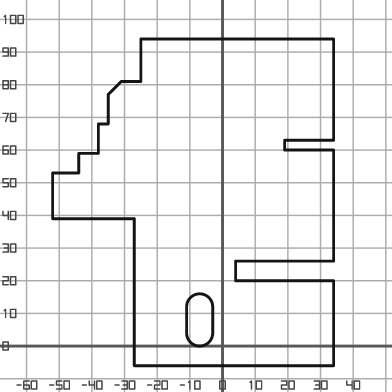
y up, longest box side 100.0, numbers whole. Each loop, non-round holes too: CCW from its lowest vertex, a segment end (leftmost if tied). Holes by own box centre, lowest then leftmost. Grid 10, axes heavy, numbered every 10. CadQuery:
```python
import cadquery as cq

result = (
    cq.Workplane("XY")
    .moveTo(-27.0, -6.0)
    .lineTo(34.0, -6.0)
    .lineTo(34.0, 20.0)
    .lineTo(4.0, 20.0)
    .lineTo(4.0, 26.0)
    .lineTo(34.0, 26.0)
    .lineTo(34.0, 60.0)
    .lineTo(19.0, 60.0)
    .lineTo(19.0, 63.0)
    .lineTo(34.0, 63.0)
    .lineTo(34.0, 94.0)
    .lineTo(-25.0, 94.0)
    .lineTo(-25.0, 81.0)
    .lineTo(-31.0, 81.0)
    .lineTo(-35.0, 77.0)
    .lineTo(-35.0, 68.0)
    .lineTo(-38.0, 68.0)
    .lineTo(-38.0, 59.0)
    .lineTo(-44.0, 59.0)
    .lineTo(-44.0, 53.0)
    .lineTo(-52.0, 53.0)
    .lineTo(-52.0, 39.0)
    .lineTo(-27.0, 39.0)
    .close()
    .moveTo(-11.0, 4.0)
    .threePointArc((-7.0, 0.0), (-3.0, 4.0))
    .lineTo(-3.0, 12.0)
    .threePointArc((-7.0, 16.0), (-11.0, 12.0))
    .close()
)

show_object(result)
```